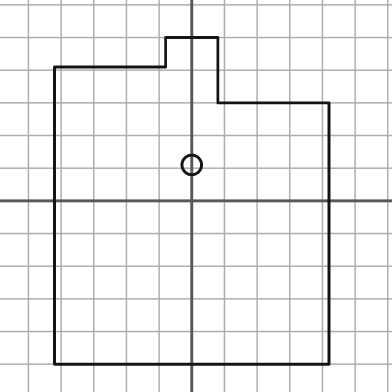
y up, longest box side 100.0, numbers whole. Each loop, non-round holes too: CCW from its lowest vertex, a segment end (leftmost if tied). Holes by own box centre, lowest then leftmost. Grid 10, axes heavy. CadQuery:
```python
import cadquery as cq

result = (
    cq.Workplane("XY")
    .moveTo(-42.0, -50.0)
    .lineTo(42.0, -50.0)
    .lineTo(42.0, 30.0)
    .lineTo(8.0, 30.0)
    .lineTo(8.0, 50.0)
    .lineTo(-8.0, 50.0)
    .lineTo(-8.0, 41.0)
    .lineTo(-42.0, 41.0)
    .close()
    .moveTo(0.0, 11.0)
    .circle(3.0)
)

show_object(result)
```